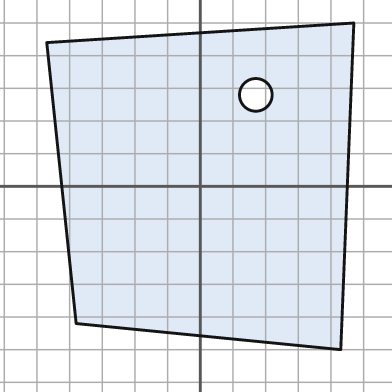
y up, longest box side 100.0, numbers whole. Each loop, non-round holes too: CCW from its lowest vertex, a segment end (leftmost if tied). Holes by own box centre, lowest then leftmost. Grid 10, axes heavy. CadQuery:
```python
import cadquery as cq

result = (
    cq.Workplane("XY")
    .moveTo(43.0, -50.0)
    .lineTo(47.0, 50.0)
    .lineTo(-47.0, 44.0)
    .lineTo(-38.0, -42.0)
    .close()
    .moveTo(17.0, 28.0)
    .circle(5.0)
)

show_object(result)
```